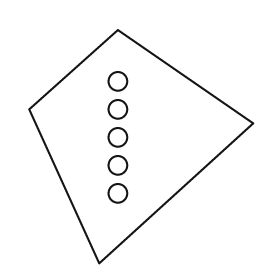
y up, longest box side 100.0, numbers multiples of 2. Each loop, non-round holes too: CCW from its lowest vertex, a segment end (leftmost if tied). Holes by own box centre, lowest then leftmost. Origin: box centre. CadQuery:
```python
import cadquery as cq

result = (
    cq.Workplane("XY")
    .moveTo(-18.0, -50.0)
    .lineTo(48.0, 10.0)
    .lineTo(-10.0, 50.0)
    .lineTo(-48.0, 16.0)
    .close()
    .moveTo(-10.0, -20.0)
    .circle(4.0)
    .moveTo(-10.0, -8.0)
    .circle(4.0)
    .moveTo(-10.0, 4.0)
    .circle(4.0)
    .moveTo(-10.0, 16.0)
    .circle(4.0)
    .moveTo(-10.0, 28.0)
    .circle(4.0)
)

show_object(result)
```